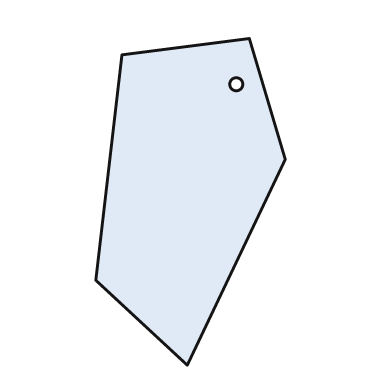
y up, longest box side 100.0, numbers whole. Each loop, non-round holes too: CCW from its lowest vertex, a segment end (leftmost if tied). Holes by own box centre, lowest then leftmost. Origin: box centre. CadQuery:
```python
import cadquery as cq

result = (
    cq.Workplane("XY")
    .moveTo(-1.0, -50.0)
    .lineTo(29.0, 13.0)
    .lineTo(18.0, 50.0)
    .lineTo(-21.0, 45.0)
    .lineTo(-29.0, -24.0)
    .close()
    .moveTo(14.0, 36.0)
    .circle(2.0)
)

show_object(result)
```